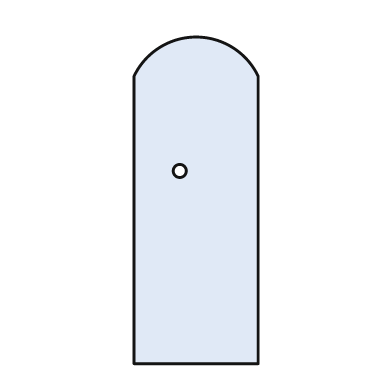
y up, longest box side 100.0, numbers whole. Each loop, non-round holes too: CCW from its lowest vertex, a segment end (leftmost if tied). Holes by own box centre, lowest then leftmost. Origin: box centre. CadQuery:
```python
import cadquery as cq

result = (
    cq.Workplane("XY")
    .moveTo(-19.0, -50.0)
    .lineTo(19.0, -50.0)
    .lineTo(19.0, 38.0)
    .threePointArc((0.0, 50.0), (-19.0, 38.0))
    .close()
    .moveTo(-5.0, 9.0)
    .circle(2.0)
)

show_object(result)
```